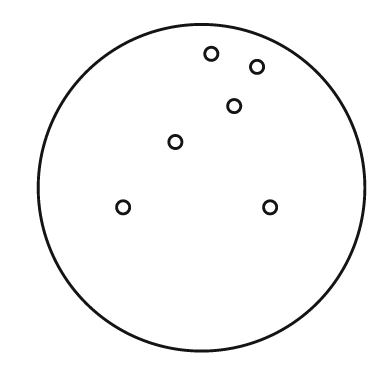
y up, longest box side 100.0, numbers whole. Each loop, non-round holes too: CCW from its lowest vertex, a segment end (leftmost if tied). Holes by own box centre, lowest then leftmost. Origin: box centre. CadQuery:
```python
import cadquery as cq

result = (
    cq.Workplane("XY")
    .moveTo(0.0, 0.0)
    .circle(50.0)
    .moveTo(-24.0, -6.0)
    .circle(2.0)
    .moveTo(21.0, -6.0)
    .circle(2.0)
    .moveTo(-8.0, 14.0)
    .circle(2.0)
    .moveTo(10.0, 25.0)
    .circle(2.0)
    .moveTo(17.0, 37.0)
    .circle(2.0)
    .moveTo(3.0, 41.0)
    .circle(2.0)
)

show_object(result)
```